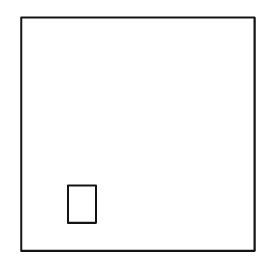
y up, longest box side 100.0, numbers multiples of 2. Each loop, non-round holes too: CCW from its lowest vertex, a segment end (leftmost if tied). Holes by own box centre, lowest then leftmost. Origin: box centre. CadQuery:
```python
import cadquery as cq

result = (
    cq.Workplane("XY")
    .moveTo(-50.0, -50.0)
    .lineTo(50.0, -50.0)
    .lineTo(50.0, 50.0)
    .lineTo(-50.0, 50.0)
    .close()
    .moveTo(-30.0, -38.0)
    .lineTo(-18.0, -38.0)
    .lineTo(-18.0, -22.0)
    .lineTo(-30.0, -22.0)
    .close()
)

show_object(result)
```